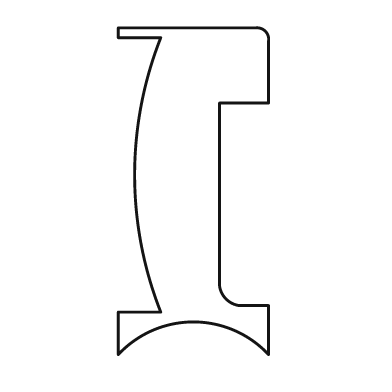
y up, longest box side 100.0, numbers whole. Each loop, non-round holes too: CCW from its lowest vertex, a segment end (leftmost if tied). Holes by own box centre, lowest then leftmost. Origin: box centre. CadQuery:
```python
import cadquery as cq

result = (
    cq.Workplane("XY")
    .moveTo(-23.0, -50.0)
    .threePointArc((0.0, -40.0), (23.0, -50.0))
    .lineTo(23.0, -35.0)
    .lineTo(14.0, -35.0)
    .threePointArc((10.0, -33.0), (8.0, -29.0))
    .lineTo(8.0, 27.0)
    .lineTo(23.0, 27.0)
    .lineTo(23.0, 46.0)
    .threePointArc((22.0, 49.0), (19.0, 50.0))
    .lineTo(-23.0, 50.0)
    .lineTo(-23.0, 47.0)
    .lineTo(-10.0, 47.0)
    .threePointArc((-18.0, 5.0), (-10.0, -37.0))
    .lineTo(-23.0, -37.0)
    .close()
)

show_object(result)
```